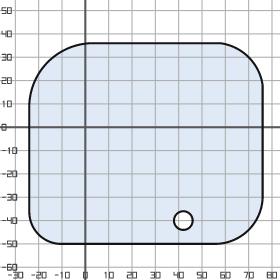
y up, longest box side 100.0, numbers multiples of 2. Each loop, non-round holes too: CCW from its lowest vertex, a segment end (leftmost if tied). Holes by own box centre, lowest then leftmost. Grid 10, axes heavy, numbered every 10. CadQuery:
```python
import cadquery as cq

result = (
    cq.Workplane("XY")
    .moveTo(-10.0, -50.0)
    .lineTo(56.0, -50.0)
    .threePointArc((70.0, -44.0), (76.0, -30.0))
    .lineTo(76.0, 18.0)
    .threePointArc((70.0, 30.0), (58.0, 36.0))
    .lineTo(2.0, 36.0)
    .threePointArc((-16.0, 28.0), (-24.0, 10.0))
    .lineTo(-24.0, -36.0)
    .threePointArc((-20.0, -46.0), (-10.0, -50.0))
    .close()
    .moveTo(42.0, -40.0)
    .circle(4.0)
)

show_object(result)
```